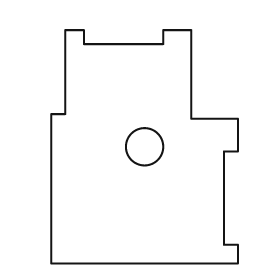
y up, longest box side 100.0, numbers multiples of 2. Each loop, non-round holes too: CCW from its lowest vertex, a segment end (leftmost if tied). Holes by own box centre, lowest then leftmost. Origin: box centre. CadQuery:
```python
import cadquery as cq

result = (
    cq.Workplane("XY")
    .moveTo(-40.0, -50.0)
    .lineTo(40.0, -50.0)
    .lineTo(40.0, -42.0)
    .lineTo(34.0, -42.0)
    .lineTo(34.0, -2.0)
    .lineTo(40.0, -2.0)
    .lineTo(40.0, 12.0)
    .lineTo(20.0, 12.0)
    .lineTo(20.0, 50.0)
    .lineTo(8.0, 50.0)
    .lineTo(8.0, 44.0)
    .lineTo(-26.0, 44.0)
    .lineTo(-26.0, 50.0)
    .lineTo(-34.0, 50.0)
    .lineTo(-34.0, 14.0)
    .lineTo(-40.0, 14.0)
    .close()
    .moveTo(0.0, 0.0)
    .circle(8.0)
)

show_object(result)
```